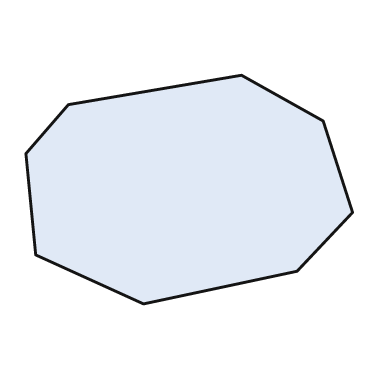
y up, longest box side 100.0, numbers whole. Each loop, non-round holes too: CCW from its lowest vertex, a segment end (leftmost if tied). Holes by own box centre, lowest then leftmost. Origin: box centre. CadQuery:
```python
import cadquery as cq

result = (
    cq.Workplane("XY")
    .moveTo(-14.0, -35.0)
    .lineTo(33.0, -25.0)
    .lineTo(50.0, -7.0)
    .lineTo(41.0, 21.0)
    .lineTo(16.0, 35.0)
    .lineTo(-37.0, 26.0)
    .lineTo(-50.0, 11.0)
    .lineTo(-47.0, -20.0)
    .close()
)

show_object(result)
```